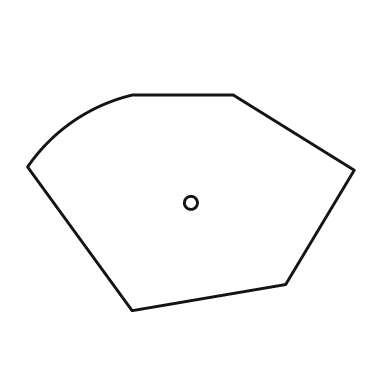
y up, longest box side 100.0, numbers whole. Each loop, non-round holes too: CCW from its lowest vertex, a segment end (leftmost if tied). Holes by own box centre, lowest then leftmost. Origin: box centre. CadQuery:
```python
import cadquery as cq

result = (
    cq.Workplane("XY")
    .moveTo(-18.0, -33.0)
    .lineTo(29.0, -25.0)
    .lineTo(50.0, 10.0)
    .lineTo(13.0, 33.0)
    .lineTo(-18.0, 33.0)
    .threePointArc((-36.0, 25.0), (-50.0, 11.0))
    .close()
    .moveTo(0.0, 0.0)
    .circle(2.0)
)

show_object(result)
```